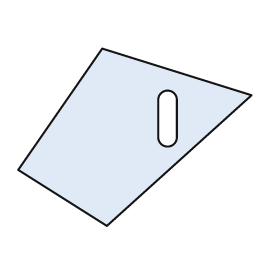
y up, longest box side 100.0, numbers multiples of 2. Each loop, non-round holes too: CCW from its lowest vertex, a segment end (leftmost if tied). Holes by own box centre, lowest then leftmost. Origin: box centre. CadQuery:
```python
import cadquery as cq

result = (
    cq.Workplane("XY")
    .moveTo(-12.0, -38.0)
    .lineTo(50.0, 18.0)
    .lineTo(-14.0, 38.0)
    .lineTo(-50.0, -14.0)
    .close()
    .moveTo(10.0, 0.0)
    .threePointArc((14.0, -4.0), (18.0, 0.0))
    .lineTo(18.0, 16.0)
    .threePointArc((14.0, 20.0), (10.0, 16.0))
    .close()
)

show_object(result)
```